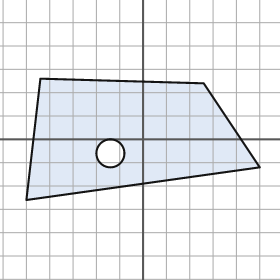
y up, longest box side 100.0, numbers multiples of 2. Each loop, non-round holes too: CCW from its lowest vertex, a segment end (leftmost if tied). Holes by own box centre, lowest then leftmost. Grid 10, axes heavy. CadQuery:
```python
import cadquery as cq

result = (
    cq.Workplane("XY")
    .moveTo(-50.0, -26.0)
    .lineTo(50.0, -12.0)
    .lineTo(26.0, 24.0)
    .lineTo(-44.0, 26.0)
    .close()
    .moveTo(-14.0, -6.0)
    .circle(6.0)
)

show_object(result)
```